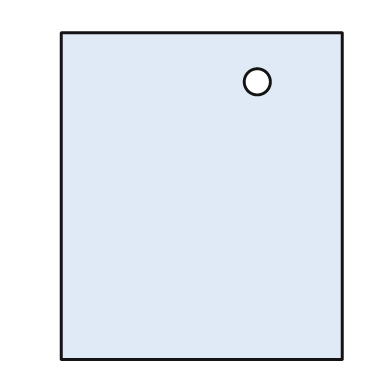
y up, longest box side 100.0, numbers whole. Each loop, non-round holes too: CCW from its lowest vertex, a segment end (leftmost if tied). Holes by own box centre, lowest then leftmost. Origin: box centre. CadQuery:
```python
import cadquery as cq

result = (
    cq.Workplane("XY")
    .moveTo(-43.0, -50.0)
    .lineTo(43.0, -50.0)
    .lineTo(43.0, 50.0)
    .lineTo(-43.0, 50.0)
    .close()
    .moveTo(17.0, 35.0)
    .circle(4.0)
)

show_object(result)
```